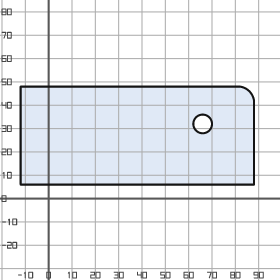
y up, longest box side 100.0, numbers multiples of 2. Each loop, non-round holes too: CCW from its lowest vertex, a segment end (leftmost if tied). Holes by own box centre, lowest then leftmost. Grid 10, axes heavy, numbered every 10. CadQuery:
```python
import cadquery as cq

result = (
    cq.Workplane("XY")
    .moveTo(-12.0, 6.0)
    .lineTo(88.0, 6.0)
    .lineTo(88.0, 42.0)
    .threePointArc((86.0, 46.0), (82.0, 48.0))
    .lineTo(-12.0, 48.0)
    .close()
    .moveTo(66.0, 32.0)
    .circle(4.0)
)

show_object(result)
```